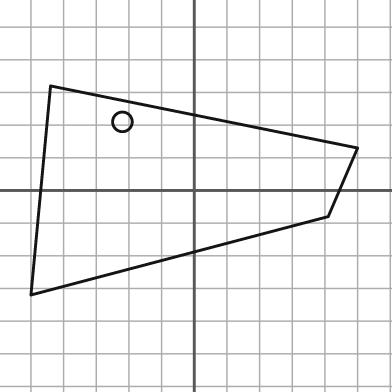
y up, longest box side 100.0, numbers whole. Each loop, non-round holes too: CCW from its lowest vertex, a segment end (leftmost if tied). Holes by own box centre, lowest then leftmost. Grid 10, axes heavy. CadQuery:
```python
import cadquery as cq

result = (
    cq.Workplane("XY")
    .moveTo(-50.0, -32.0)
    .lineTo(41.0, -8.0)
    .lineTo(50.0, 13.0)
    .lineTo(-44.0, 32.0)
    .close()
    .moveTo(-22.0, 21.0)
    .circle(3.0)
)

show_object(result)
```